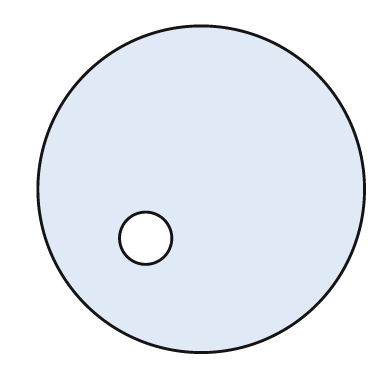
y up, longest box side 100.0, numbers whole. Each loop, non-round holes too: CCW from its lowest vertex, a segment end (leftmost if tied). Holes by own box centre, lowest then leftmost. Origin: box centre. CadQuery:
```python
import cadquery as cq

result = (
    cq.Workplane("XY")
    .moveTo(0.0, 0.0)
    .circle(50.0)
    .moveTo(-17.0, -15.0)
    .circle(8.0)
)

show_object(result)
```